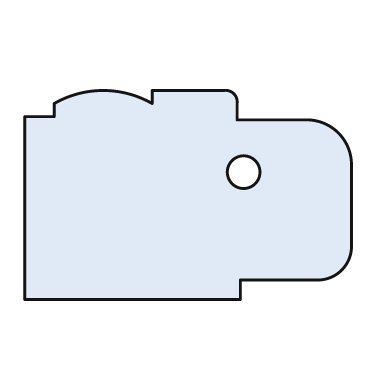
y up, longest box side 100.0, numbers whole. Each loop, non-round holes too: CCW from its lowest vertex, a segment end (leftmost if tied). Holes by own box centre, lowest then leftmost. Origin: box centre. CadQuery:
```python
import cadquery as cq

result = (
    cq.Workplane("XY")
    .moveTo(-50.0, -32.0)
    .lineTo(16.0, -32.0)
    .lineTo(16.0, -26.0)
    .lineTo(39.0, -26.0)
    .threePointArc((47.0, -23.0), (50.0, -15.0))
    .lineTo(50.0, 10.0)
    .threePointArc((46.0, 19.0), (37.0, 23.0))
    .lineTo(15.0, 23.0)
    .lineTo(15.0, 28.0)
    .threePointArc((14.0, 31.0), (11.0, 32.0))
    .lineTo(-11.0, 32.0)
    .lineTo(-11.0, 28.0)
    .threePointArc((-26.0, 32.0), (-41.0, 28.0))
    .lineTo(-41.0, 24.0)
    .lineTo(-50.0, 24.0)
    .close()
    .moveTo(17.0, 7.0)
    .circle(5.0)
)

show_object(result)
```